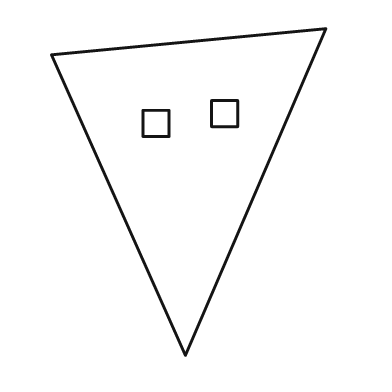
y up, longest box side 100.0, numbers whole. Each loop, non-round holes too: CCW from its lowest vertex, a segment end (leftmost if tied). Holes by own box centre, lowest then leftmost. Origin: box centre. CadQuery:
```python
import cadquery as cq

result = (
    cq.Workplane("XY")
    .moveTo(-1.0, -50.0)
    .lineTo(42.0, 50.0)
    .lineTo(-42.0, 42.0)
    .close()
    .moveTo(-14.0, 17.0)
    .lineTo(-6.0, 17.0)
    .lineTo(-6.0, 25.0)
    .lineTo(-14.0, 25.0)
    .close()
    .moveTo(7.0, 20.0)
    .lineTo(15.0, 20.0)
    .lineTo(15.0, 28.0)
    .lineTo(7.0, 28.0)
    .close()
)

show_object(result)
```